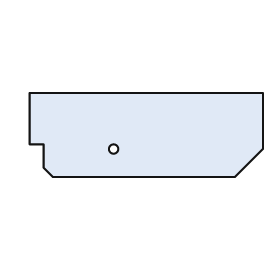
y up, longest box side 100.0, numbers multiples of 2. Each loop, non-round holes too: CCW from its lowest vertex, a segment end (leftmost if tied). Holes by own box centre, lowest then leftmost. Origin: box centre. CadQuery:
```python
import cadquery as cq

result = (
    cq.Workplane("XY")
    .moveTo(-40.0, -18.0)
    .lineTo(38.0, -18.0)
    .lineTo(50.0, -6.0)
    .lineTo(50.0, 18.0)
    .lineTo(-50.0, 18.0)
    .lineTo(-50.0, -4.0)
    .lineTo(-44.0, -4.0)
    .lineTo(-44.0, -14.0)
    .close()
    .moveTo(-14.0, -6.0)
    .circle(2.0)
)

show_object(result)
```